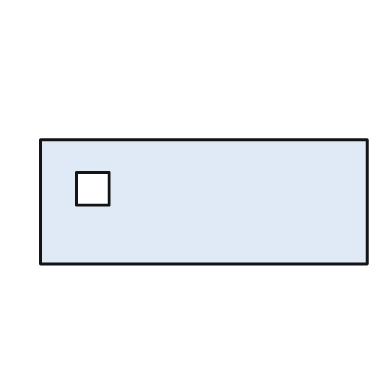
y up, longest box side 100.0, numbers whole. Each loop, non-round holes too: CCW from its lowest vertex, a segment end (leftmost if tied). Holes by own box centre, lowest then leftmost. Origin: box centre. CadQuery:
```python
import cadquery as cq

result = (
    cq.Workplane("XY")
    .moveTo(-50.0, -19.0)
    .lineTo(50.0, -19.0)
    .lineTo(50.0, 19.0)
    .lineTo(-50.0, 19.0)
    .close()
    .moveTo(-39.0, -1.0)
    .lineTo(-29.0, -1.0)
    .lineTo(-29.0, 9.0)
    .lineTo(-39.0, 9.0)
    .close()
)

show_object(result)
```